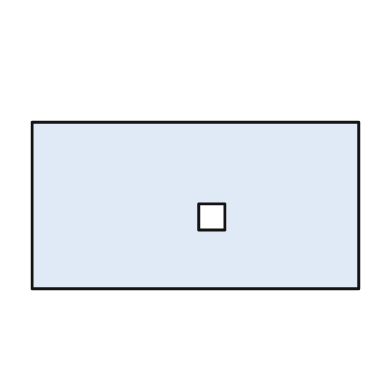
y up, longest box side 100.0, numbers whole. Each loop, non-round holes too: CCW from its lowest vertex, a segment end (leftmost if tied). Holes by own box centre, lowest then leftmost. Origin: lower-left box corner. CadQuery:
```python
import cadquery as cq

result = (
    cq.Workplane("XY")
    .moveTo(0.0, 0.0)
    .lineTo(100.0, 0.0)
    .lineTo(100.0, 51.0)
    .lineTo(0.0, 51.0)
    .close()
    .moveTo(51.0, 18.0)
    .lineTo(59.0, 18.0)
    .lineTo(59.0, 26.0)
    .lineTo(51.0, 26.0)
    .close()
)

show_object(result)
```